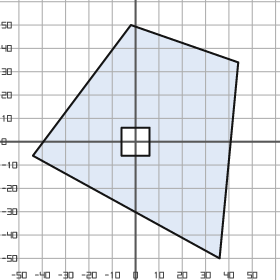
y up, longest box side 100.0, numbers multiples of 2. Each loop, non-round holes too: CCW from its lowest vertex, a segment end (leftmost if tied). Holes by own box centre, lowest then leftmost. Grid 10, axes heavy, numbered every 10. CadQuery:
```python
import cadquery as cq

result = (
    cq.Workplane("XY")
    .moveTo(36.0, -50.0)
    .lineTo(44.0, 34.0)
    .lineTo(-2.0, 50.0)
    .lineTo(-44.0, -6.0)
    .close()
    .moveTo(-6.0, -6.0)
    .lineTo(6.0, -6.0)
    .lineTo(6.0, 6.0)
    .lineTo(-6.0, 6.0)
    .close()
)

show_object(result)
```